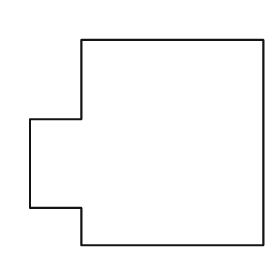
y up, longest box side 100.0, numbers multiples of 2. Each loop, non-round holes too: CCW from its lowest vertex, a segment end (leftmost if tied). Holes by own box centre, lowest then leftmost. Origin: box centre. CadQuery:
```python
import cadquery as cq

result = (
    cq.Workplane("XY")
    .moveTo(-28.0, -44.0)
    .lineTo(50.0, -44.0)
    .lineTo(50.0, 44.0)
    .lineTo(-28.0, 44.0)
    .lineTo(-28.0, 10.0)
    .lineTo(-50.0, 10.0)
    .lineTo(-50.0, -28.0)
    .lineTo(-28.0, -28.0)
    .close()
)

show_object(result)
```